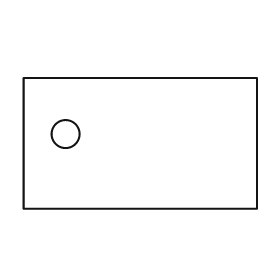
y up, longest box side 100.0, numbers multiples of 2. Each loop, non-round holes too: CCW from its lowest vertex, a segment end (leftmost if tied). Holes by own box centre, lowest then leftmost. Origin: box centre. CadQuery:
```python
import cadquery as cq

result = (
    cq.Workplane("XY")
    .moveTo(-50.0, -28.0)
    .lineTo(50.0, -28.0)
    .lineTo(50.0, 28.0)
    .lineTo(-50.0, 28.0)
    .close()
    .moveTo(-32.0, 4.0)
    .circle(6.0)
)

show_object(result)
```